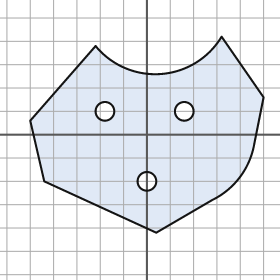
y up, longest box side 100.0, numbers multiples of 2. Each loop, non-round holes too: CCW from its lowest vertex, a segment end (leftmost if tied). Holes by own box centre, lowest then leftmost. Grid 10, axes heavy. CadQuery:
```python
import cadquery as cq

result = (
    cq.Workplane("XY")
    .moveTo(4.0, -42.0)
    .lineTo(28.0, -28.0)
    .threePointArc((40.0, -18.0), (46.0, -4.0))
    .lineTo(50.0, 16.0)
    .lineTo(32.0, 42.0)
    .threePointArc((6.0, 26.0), (-22.0, 38.0))
    .lineTo(-50.0, 6.0)
    .lineTo(-44.0, -20.0)
    .close()
    .moveTo(0.0, -20.0)
    .circle(4.0)
    .moveTo(-18.0, 10.0)
    .circle(4.0)
    .moveTo(16.0, 10.0)
    .circle(4.0)
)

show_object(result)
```